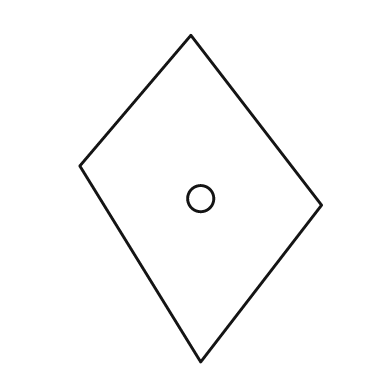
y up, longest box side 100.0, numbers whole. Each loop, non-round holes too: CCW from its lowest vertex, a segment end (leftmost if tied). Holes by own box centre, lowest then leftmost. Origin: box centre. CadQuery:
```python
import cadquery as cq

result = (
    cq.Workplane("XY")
    .moveTo(0.0, -50.0)
    .lineTo(37.0, -2.0)
    .lineTo(-3.0, 50.0)
    .lineTo(-37.0, 10.0)
    .close()
    .moveTo(0.0, 0.0)
    .circle(4.0)
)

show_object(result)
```